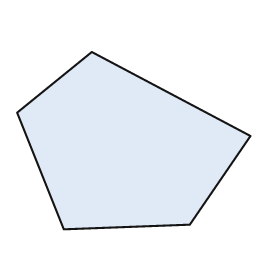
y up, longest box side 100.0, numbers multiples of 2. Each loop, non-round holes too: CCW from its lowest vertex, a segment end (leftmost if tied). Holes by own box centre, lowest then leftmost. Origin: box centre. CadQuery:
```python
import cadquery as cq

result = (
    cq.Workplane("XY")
    .moveTo(-30.0, -38.0)
    .lineTo(24.0, -36.0)
    .lineTo(50.0, 2.0)
    .lineTo(-18.0, 38.0)
    .lineTo(-50.0, 12.0)
    .close()
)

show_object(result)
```